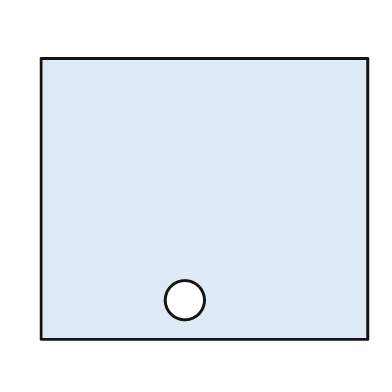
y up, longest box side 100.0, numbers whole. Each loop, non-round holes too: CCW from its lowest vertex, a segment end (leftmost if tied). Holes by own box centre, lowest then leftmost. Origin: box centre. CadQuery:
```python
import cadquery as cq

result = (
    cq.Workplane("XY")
    .moveTo(-50.0, -43.0)
    .lineTo(50.0, -43.0)
    .lineTo(50.0, 43.0)
    .lineTo(-50.0, 43.0)
    .close()
    .moveTo(-6.0, -31.0)
    .circle(6.0)
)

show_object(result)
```